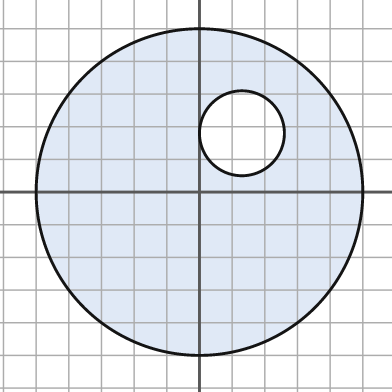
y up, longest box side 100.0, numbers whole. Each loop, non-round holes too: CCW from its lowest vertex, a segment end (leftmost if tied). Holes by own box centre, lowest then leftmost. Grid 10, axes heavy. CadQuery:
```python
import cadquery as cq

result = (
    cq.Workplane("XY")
    .moveTo(0.0, 0.0)
    .circle(50.0)
    .moveTo(13.0, 18.0)
    .circle(13.0)
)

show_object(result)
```